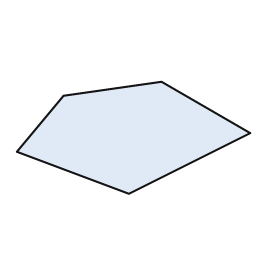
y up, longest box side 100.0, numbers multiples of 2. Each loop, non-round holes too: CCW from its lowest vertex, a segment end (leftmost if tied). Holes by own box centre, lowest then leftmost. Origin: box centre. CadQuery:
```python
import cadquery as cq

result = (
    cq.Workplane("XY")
    .moveTo(-2.0, -24.0)
    .lineTo(50.0, 2.0)
    .lineTo(12.0, 24.0)
    .lineTo(-30.0, 18.0)
    .lineTo(-50.0, -6.0)
    .close()
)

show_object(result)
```